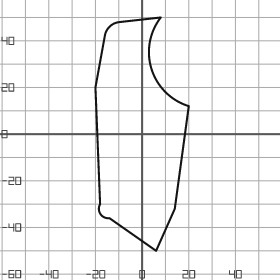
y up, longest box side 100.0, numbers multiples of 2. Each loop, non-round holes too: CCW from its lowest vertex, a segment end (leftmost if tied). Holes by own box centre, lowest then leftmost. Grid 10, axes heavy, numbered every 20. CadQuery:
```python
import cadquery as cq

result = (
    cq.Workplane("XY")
    .moveTo(6.0, -50.0)
    .lineTo(14.0, -32.0)
    .lineTo(20.0, 12.0)
    .threePointArc((4.0, 28.0), (8.0, 50.0))
    .lineTo(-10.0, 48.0)
    .threePointArc((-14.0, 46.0), (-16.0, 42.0))
    .lineTo(-20.0, 20.0)
    .lineTo(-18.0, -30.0)
    .threePointArc((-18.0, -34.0), (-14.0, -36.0))
    .close()
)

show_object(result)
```